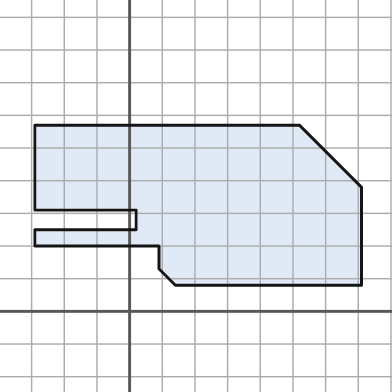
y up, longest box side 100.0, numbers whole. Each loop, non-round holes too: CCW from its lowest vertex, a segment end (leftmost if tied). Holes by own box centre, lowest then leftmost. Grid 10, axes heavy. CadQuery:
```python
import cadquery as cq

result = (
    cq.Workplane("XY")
    .moveTo(14.0, 8.0)
    .lineTo(71.0, 8.0)
    .lineTo(71.0, 38.0)
    .lineTo(52.0, 57.0)
    .lineTo(-29.0, 57.0)
    .lineTo(-29.0, 31.0)
    .lineTo(2.0, 31.0)
    .lineTo(2.0, 25.0)
    .lineTo(-29.0, 25.0)
    .lineTo(-29.0, 20.0)
    .lineTo(9.0, 20.0)
    .lineTo(9.0, 13.0)
    .close()
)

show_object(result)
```